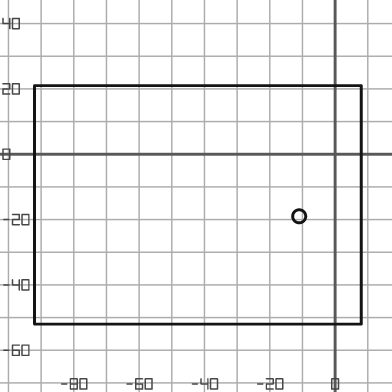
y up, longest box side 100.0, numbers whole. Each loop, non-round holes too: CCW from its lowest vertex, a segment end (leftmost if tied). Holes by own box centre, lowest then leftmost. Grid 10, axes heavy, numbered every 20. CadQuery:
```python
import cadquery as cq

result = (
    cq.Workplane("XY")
    .moveTo(-92.0, -52.0)
    .lineTo(8.0, -52.0)
    .lineTo(8.0, 21.0)
    .lineTo(-92.0, 21.0)
    .close()
    .moveTo(-11.0, -19.0)
    .circle(2.0)
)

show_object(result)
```